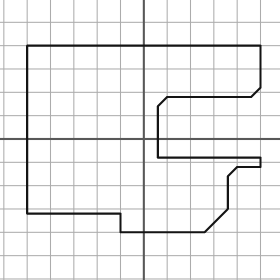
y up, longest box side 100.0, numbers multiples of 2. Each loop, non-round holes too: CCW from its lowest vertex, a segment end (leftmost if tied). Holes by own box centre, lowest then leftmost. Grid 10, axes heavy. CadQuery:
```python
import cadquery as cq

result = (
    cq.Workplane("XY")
    .moveTo(-10.0, -40.0)
    .lineTo(26.0, -40.0)
    .lineTo(36.0, -30.0)
    .lineTo(36.0, -16.0)
    .lineTo(40.0, -12.0)
    .lineTo(50.0, -12.0)
    .lineTo(50.0, -8.0)
    .lineTo(6.0, -8.0)
    .lineTo(6.0, 14.0)
    .lineTo(10.0, 18.0)
    .lineTo(46.0, 18.0)
    .lineTo(50.0, 22.0)
    .lineTo(50.0, 40.0)
    .lineTo(-50.0, 40.0)
    .lineTo(-50.0, -32.0)
    .lineTo(-10.0, -32.0)
    .close()
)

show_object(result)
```